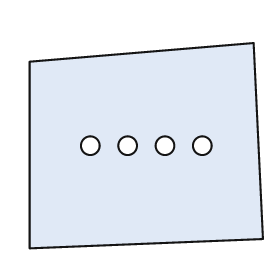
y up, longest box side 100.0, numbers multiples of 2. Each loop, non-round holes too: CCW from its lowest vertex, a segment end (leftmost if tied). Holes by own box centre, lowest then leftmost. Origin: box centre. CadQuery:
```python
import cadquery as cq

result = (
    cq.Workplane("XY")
    .moveTo(-50.0, -44.0)
    .lineTo(50.0, -40.0)
    .lineTo(46.0, 44.0)
    .lineTo(-50.0, 36.0)
    .close()
    .moveTo(-24.0, 0.0)
    .circle(4.0)
    .moveTo(-8.0, 0.0)
    .circle(4.0)
    .moveTo(8.0, 0.0)
    .circle(4.0)
    .moveTo(24.0, 0.0)
    .circle(4.0)
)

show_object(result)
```